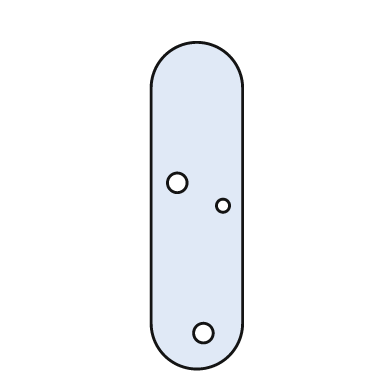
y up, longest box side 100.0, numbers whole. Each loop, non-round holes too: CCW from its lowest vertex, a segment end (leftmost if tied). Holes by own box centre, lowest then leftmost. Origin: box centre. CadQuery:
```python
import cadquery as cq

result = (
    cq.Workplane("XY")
    .moveTo(-14.0, -36.0)
    .threePointArc((0.0, -50.0), (14.0, -36.0))
    .lineTo(14.0, 36.0)
    .threePointArc((0.0, 50.0), (-14.0, 36.0))
    .close()
    .moveTo(2.0, -39.0)
    .circle(3.0)
    .moveTo(8.0, 0.0)
    .circle(2.0)
    .moveTo(-6.0, 7.0)
    .circle(3.0)
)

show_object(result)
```